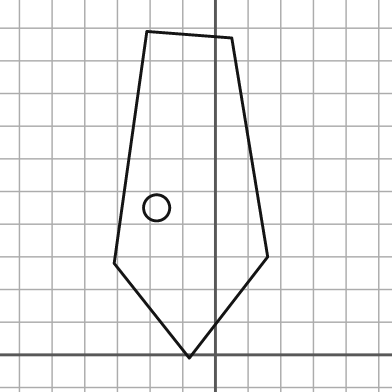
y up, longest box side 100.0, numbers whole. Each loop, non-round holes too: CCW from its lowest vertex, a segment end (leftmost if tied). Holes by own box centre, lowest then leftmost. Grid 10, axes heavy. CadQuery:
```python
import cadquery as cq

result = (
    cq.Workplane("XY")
    .moveTo(-8.0, -1.0)
    .lineTo(16.0, 30.0)
    .lineTo(5.0, 97.0)
    .lineTo(-21.0, 99.0)
    .lineTo(-31.0, 28.0)
    .close()
    .moveTo(-18.0, 45.0)
    .circle(4.0)
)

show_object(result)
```